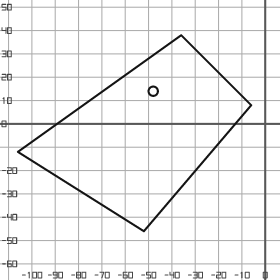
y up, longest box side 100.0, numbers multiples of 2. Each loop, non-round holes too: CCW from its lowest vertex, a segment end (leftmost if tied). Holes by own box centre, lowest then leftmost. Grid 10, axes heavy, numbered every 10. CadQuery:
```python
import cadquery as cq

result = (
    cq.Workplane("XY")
    .moveTo(-52.0, -46.0)
    .lineTo(-6.0, 8.0)
    .lineTo(-36.0, 38.0)
    .lineTo(-106.0, -12.0)
    .close()
    .moveTo(-48.0, 14.0)
    .circle(2.0)
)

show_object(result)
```